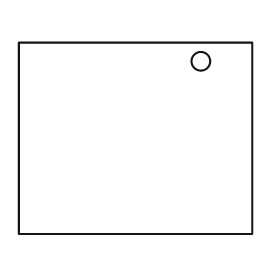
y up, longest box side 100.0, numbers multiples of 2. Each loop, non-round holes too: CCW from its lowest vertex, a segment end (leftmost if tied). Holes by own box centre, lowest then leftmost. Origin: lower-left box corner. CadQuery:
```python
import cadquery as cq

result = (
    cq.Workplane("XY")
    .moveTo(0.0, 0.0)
    .lineTo(100.0, 0.0)
    .lineTo(100.0, 82.0)
    .lineTo(0.0, 82.0)
    .close()
    .moveTo(78.0, 74.0)
    .circle(4.0)
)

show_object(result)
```